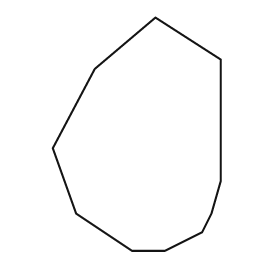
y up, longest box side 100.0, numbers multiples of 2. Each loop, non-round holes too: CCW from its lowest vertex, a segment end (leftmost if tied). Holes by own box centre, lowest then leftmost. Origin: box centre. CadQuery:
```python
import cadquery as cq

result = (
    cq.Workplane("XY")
    .moveTo(-2.0, -50.0)
    .lineTo(12.0, -50.0)
    .lineTo(28.0, -42.0)
    .lineTo(32.0, -34.0)
    .lineTo(36.0, -20.0)
    .lineTo(36.0, 32.0)
    .lineTo(8.0, 50.0)
    .lineTo(-18.0, 28.0)
    .lineTo(-36.0, -6.0)
    .lineTo(-26.0, -34.0)
    .close()
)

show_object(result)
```